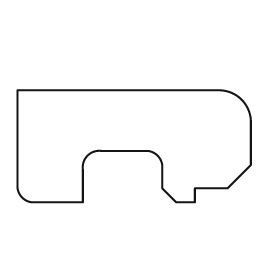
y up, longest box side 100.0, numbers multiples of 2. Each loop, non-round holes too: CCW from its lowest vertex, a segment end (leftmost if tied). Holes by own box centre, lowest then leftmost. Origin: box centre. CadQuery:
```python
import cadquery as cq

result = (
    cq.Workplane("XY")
    .moveTo(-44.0, -24.0)
    .lineTo(-22.0, -24.0)
    .lineTo(-22.0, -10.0)
    .threePointArc((-20.0, -4.0), (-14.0, -2.0))
    .lineTo(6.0, -2.0)
    .threePointArc((10.0, -4.0), (12.0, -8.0))
    .lineTo(12.0, -18.0)
    .lineTo(18.0, -24.0)
    .lineTo(26.0, -24.0)
    .lineTo(26.0, -18.0)
    .lineTo(40.0, -18.0)
    .lineTo(50.0, -8.0)
    .lineTo(50.0, 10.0)
    .threePointArc((46.0, 20.0), (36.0, 24.0))
    .lineTo(-50.0, 24.0)
    .lineTo(-50.0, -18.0)
    .threePointArc((-48.0, -22.0), (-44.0, -24.0))
    .close()
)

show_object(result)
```